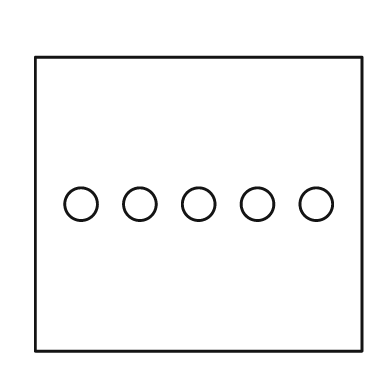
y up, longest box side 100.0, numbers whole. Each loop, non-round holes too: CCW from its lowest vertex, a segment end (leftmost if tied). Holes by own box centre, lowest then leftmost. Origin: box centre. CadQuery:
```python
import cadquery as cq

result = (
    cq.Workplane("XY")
    .moveTo(-50.0, -45.0)
    .lineTo(50.0, -45.0)
    .lineTo(50.0, 45.0)
    .lineTo(-50.0, 45.0)
    .close()
    .moveTo(-36.0, 0.0)
    .circle(5.0)
    .moveTo(-18.0, 0.0)
    .circle(5.0)
    .moveTo(0.0, 0.0)
    .circle(5.0)
    .moveTo(18.0, 0.0)
    .circle(5.0)
    .moveTo(36.0, 0.0)
    .circle(5.0)
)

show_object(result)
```